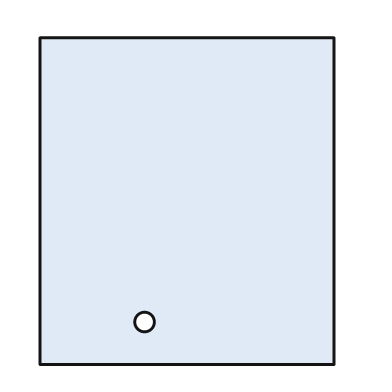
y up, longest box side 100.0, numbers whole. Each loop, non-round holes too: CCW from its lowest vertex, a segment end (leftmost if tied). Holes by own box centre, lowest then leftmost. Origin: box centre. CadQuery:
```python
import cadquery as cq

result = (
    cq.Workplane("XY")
    .moveTo(-45.0, -50.0)
    .lineTo(45.0, -50.0)
    .lineTo(45.0, 50.0)
    .lineTo(-45.0, 50.0)
    .close()
    .moveTo(-13.0, -37.0)
    .circle(3.0)
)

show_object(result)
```